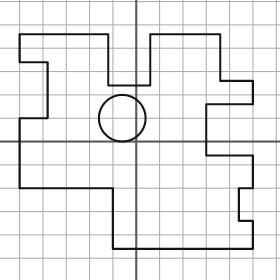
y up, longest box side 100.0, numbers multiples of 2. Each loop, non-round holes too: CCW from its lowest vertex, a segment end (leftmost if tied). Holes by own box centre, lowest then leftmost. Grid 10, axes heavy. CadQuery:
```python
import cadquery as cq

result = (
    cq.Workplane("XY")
    .moveTo(-10.0, -46.0)
    .lineTo(50.0, -46.0)
    .lineTo(50.0, -34.0)
    .lineTo(44.0, -34.0)
    .lineTo(44.0, -20.0)
    .lineTo(50.0, -20.0)
    .lineTo(50.0, -6.0)
    .lineTo(30.0, -6.0)
    .lineTo(30.0, 16.0)
    .lineTo(50.0, 16.0)
    .lineTo(50.0, 26.0)
    .lineTo(36.0, 26.0)
    .lineTo(36.0, 46.0)
    .lineTo(6.0, 46.0)
    .lineTo(6.0, 24.0)
    .lineTo(-12.0, 24.0)
    .lineTo(-12.0, 46.0)
    .lineTo(-50.0, 46.0)
    .lineTo(-50.0, 34.0)
    .lineTo(-38.0, 34.0)
    .lineTo(-38.0, 10.0)
    .lineTo(-50.0, 10.0)
    .lineTo(-50.0, -20.0)
    .lineTo(-10.0, -20.0)
    .close()
    .moveTo(-6.0, 10.0)
    .circle(10.0)
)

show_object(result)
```